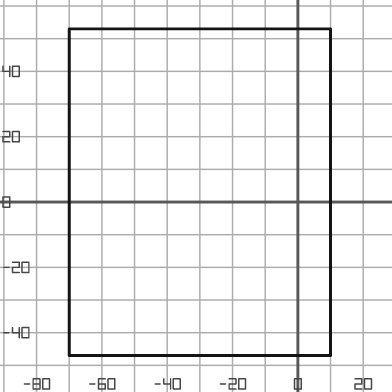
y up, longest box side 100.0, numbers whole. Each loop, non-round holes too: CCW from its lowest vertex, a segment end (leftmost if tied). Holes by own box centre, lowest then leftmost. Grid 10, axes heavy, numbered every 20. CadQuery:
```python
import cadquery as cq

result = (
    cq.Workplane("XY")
    .moveTo(-70.0, -47.0)
    .lineTo(10.0, -47.0)
    .lineTo(10.0, 53.0)
    .lineTo(-70.0, 53.0)
    .close()
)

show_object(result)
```